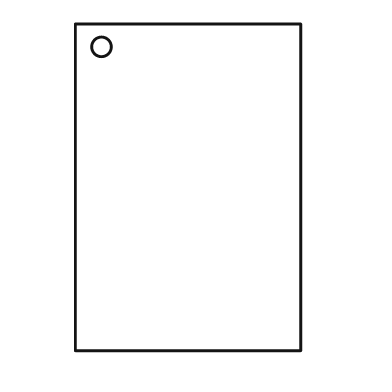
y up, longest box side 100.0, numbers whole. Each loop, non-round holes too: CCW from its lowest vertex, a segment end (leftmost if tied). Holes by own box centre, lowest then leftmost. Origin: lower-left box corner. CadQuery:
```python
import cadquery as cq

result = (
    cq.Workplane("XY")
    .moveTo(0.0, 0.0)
    .lineTo(69.0, 0.0)
    .lineTo(69.0, 100.0)
    .lineTo(0.0, 100.0)
    .close()
    .moveTo(8.0, 93.0)
    .circle(3.0)
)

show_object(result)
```